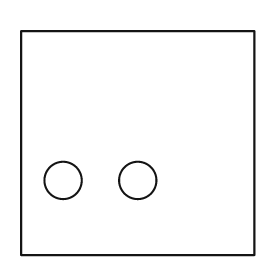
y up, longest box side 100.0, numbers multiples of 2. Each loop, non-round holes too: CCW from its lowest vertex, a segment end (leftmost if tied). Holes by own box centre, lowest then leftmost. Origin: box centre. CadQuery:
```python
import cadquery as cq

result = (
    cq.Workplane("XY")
    .moveTo(-50.0, -48.0)
    .lineTo(50.0, -48.0)
    .lineTo(50.0, 48.0)
    .lineTo(-50.0, 48.0)
    .close()
    .moveTo(-32.0, -16.0)
    .circle(8.0)
    .moveTo(0.0, -16.0)
    .circle(8.0)
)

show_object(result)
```